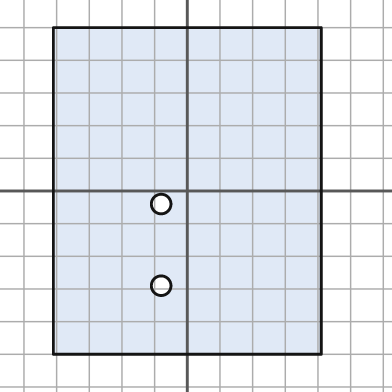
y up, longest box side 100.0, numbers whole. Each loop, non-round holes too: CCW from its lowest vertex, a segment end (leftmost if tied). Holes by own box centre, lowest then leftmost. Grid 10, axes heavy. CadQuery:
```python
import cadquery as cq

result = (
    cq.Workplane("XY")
    .moveTo(-41.0, -50.0)
    .lineTo(41.0, -50.0)
    .lineTo(41.0, 50.0)
    .lineTo(-41.0, 50.0)
    .close()
    .moveTo(-8.0, -29.0)
    .circle(3.0)
    .moveTo(-8.0, -4.0)
    .circle(3.0)
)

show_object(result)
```